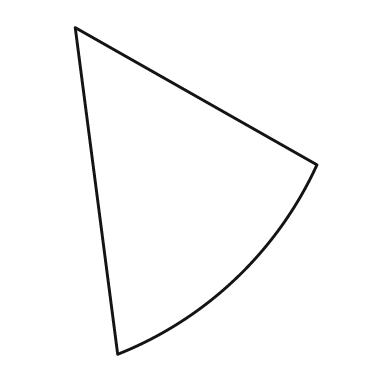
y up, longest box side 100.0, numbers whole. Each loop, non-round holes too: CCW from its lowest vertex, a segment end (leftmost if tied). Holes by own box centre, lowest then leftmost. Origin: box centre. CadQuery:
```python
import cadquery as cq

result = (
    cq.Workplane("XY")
    .moveTo(-24.0, -50.0)
    .threePointArc((12.0, -27.0), (37.0, 8.0))
    .lineTo(-37.0, 50.0)
    .close()
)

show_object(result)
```